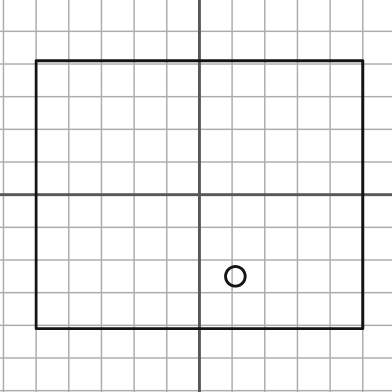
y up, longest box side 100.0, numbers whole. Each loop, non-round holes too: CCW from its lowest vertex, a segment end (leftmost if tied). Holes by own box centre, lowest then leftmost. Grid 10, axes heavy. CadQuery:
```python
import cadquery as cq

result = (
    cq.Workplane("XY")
    .moveTo(-50.0, -41.0)
    .lineTo(50.0, -41.0)
    .lineTo(50.0, 41.0)
    .lineTo(-50.0, 41.0)
    .close()
    .moveTo(11.0, -25.0)
    .circle(3.0)
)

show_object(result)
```